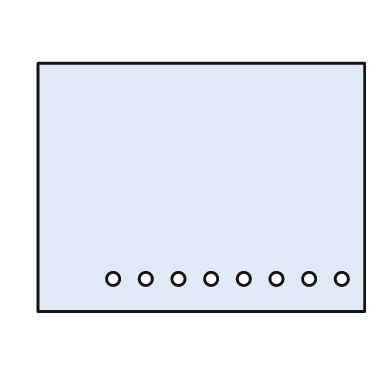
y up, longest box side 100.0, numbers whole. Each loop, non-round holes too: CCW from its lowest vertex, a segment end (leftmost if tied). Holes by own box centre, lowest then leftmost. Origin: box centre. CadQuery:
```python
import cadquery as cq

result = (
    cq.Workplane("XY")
    .moveTo(-50.0, -38.0)
    .lineTo(50.0, -38.0)
    .lineTo(50.0, 38.0)
    .lineTo(-50.0, 38.0)
    .close()
    .moveTo(-27.0, -28.0)
    .circle(2.0)
    .moveTo(-17.0, -28.0)
    .circle(2.0)
    .moveTo(-7.0, -28.0)
    .circle(2.0)
    .moveTo(3.0, -28.0)
    .circle(2.0)
    .moveTo(13.0, -28.0)
    .circle(2.0)
    .moveTo(23.0, -28.0)
    .circle(2.0)
    .moveTo(33.0, -28.0)
    .circle(2.0)
    .moveTo(43.0, -28.0)
    .circle(2.0)
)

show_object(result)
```